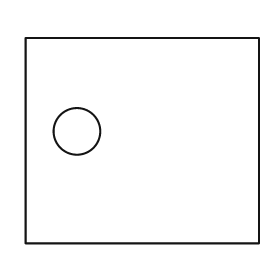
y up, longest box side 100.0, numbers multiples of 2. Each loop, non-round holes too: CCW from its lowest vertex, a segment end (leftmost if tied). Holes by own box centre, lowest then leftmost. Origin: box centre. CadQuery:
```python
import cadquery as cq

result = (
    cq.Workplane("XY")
    .moveTo(-50.0, -44.0)
    .lineTo(50.0, -44.0)
    .lineTo(50.0, 44.0)
    .lineTo(-50.0, 44.0)
    .close()
    .moveTo(-28.0, 4.0)
    .circle(10.0)
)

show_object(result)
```